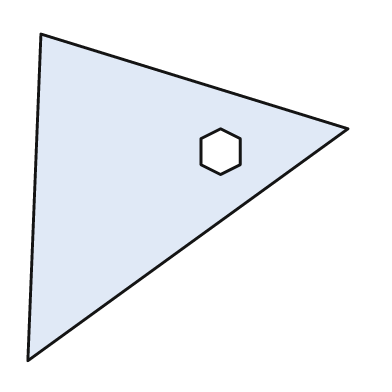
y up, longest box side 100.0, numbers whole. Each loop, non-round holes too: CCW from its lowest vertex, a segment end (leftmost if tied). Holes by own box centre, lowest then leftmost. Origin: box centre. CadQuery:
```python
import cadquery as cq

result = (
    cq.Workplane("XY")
    .moveTo(-49.0, -50.0)
    .lineTo(49.0, 21.0)
    .lineTo(-45.0, 50.0)
    .close()
    .moveTo(10.0, 7.0)
    .lineTo(16.0, 10.0)
    .lineTo(16.0, 18.0)
    .lineTo(10.0, 21.0)
    .lineTo(4.0, 18.0)
    .lineTo(4.0, 10.0)
    .close()
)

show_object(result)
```